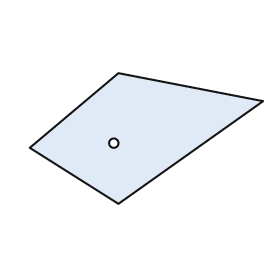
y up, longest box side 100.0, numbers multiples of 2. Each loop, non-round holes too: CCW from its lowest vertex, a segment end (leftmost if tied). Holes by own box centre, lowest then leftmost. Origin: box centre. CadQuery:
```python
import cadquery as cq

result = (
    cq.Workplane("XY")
    .moveTo(-12.0, -28.0)
    .lineTo(50.0, 16.0)
    .lineTo(-12.0, 28.0)
    .lineTo(-50.0, -4.0)
    .close()
    .moveTo(-14.0, -2.0)
    .circle(2.0)
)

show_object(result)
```